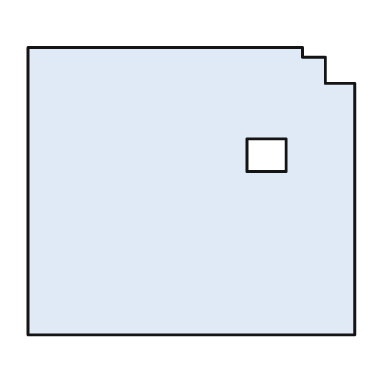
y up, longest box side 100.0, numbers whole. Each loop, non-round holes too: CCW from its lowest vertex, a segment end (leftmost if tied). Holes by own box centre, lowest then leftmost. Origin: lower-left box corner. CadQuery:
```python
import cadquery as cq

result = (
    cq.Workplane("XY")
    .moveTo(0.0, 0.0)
    .lineTo(100.0, 0.0)
    .lineTo(100.0, 77.0)
    .lineTo(91.0, 77.0)
    .lineTo(91.0, 85.0)
    .lineTo(84.0, 85.0)
    .lineTo(84.0, 88.0)
    .lineTo(0.0, 88.0)
    .close()
    .moveTo(67.0, 50.0)
    .lineTo(79.0, 50.0)
    .lineTo(79.0, 60.0)
    .lineTo(67.0, 60.0)
    .close()
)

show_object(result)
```